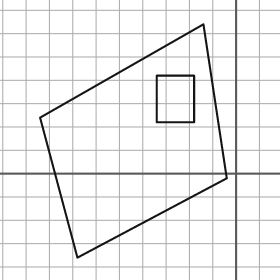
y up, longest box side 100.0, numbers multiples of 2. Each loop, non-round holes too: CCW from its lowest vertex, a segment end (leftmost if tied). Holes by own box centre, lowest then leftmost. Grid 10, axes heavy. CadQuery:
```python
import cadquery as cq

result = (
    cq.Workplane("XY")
    .moveTo(-68.0, -36.0)
    .lineTo(-4.0, -2.0)
    .lineTo(-14.0, 64.0)
    .lineTo(-84.0, 24.0)
    .close()
    .moveTo(-34.0, 22.0)
    .lineTo(-18.0, 22.0)
    .lineTo(-18.0, 42.0)
    .lineTo(-34.0, 42.0)
    .close()
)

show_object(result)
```